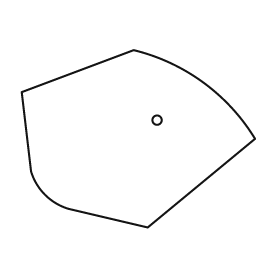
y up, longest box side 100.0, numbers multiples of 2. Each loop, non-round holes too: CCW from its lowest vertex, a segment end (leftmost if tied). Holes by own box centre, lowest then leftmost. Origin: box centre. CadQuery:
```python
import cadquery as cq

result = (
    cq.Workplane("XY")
    .moveTo(4.0, -38.0)
    .lineTo(50.0, 0.0)
    .threePointArc((28.0, 24.0), (-2.0, 38.0))
    .lineTo(-50.0, 20.0)
    .lineTo(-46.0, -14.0)
    .threePointArc((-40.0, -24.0), (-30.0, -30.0))
    .close()
    .moveTo(8.0, 8.0)
    .circle(2.0)
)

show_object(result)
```